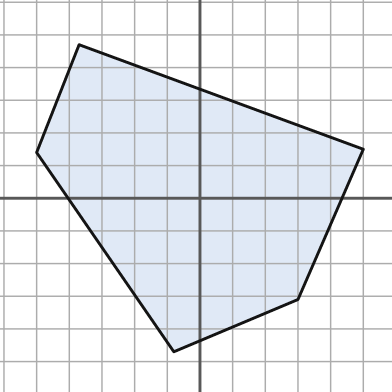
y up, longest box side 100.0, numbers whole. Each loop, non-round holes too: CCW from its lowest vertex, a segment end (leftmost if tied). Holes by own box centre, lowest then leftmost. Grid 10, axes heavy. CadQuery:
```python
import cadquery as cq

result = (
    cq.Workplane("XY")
    .moveTo(-8.0, -47.0)
    .lineTo(30.0, -31.0)
    .lineTo(50.0, 15.0)
    .lineTo(-37.0, 47.0)
    .lineTo(-50.0, 14.0)
    .close()
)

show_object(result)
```